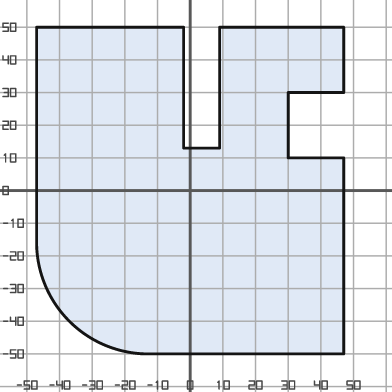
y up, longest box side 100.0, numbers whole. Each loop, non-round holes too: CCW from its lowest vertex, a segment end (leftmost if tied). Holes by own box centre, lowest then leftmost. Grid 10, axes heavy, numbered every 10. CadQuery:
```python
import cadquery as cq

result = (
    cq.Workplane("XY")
    .moveTo(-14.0, -50.0)
    .lineTo(47.0, -50.0)
    .lineTo(47.0, 10.0)
    .lineTo(30.0, 10.0)
    .lineTo(30.0, 30.0)
    .lineTo(47.0, 30.0)
    .lineTo(47.0, 50.0)
    .lineTo(9.0, 50.0)
    .lineTo(9.0, 13.0)
    .lineTo(-2.0, 13.0)
    .lineTo(-2.0, 50.0)
    .lineTo(-47.0, 50.0)
    .lineTo(-47.0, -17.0)
    .threePointArc((-37.0, -40.0), (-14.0, -50.0))
    .close()
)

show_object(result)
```